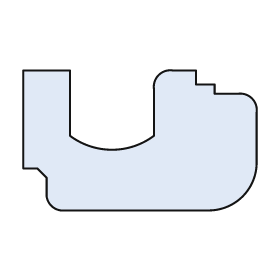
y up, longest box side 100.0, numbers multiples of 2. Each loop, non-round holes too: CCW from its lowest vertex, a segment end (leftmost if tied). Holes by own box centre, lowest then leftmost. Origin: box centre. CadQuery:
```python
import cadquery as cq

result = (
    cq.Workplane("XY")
    .moveTo(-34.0, -30.0)
    .lineTo(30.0, -30.0)
    .threePointArc((44.0, -24.0), (50.0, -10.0))
    .lineTo(50.0, 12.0)
    .threePointArc((48.0, 18.0), (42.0, 20.0))
    .lineTo(32.0, 20.0)
    .lineTo(32.0, 24.0)
    .lineTo(24.0, 24.0)
    .lineTo(24.0, 30.0)
    .lineTo(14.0, 30.0)
    .threePointArc((8.0, 28.0), (6.0, 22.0))
    .lineTo(6.0, 2.0)
    .threePointArc((-12.0, -4.0), (-30.0, 2.0))
    .lineTo(-30.0, 30.0)
    .lineTo(-50.0, 30.0)
    .lineTo(-50.0, -12.0)
    .lineTo(-44.0, -12.0)
    .lineTo(-40.0, -16.0)
    .lineTo(-40.0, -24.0)
    .threePointArc((-38.0, -28.0), (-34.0, -30.0))
    .close()
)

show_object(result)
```